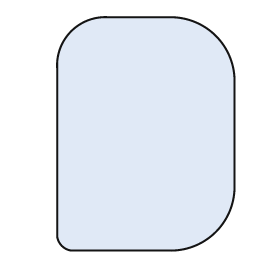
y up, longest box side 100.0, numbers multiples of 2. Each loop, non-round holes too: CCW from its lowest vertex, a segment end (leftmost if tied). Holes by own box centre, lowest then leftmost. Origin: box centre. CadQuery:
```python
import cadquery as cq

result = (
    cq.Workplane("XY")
    .moveTo(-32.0, -50.0)
    .lineTo(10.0, -50.0)
    .threePointArc((30.0, -42.0), (38.0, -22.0))
    .lineTo(38.0, 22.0)
    .threePointArc((30.0, 42.0), (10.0, 50.0))
    .lineTo(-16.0, 50.0)
    .threePointArc((-32.0, 44.0), (-38.0, 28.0))
    .lineTo(-38.0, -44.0)
    .threePointArc((-36.0, -48.0), (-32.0, -50.0))
    .close()
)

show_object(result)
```